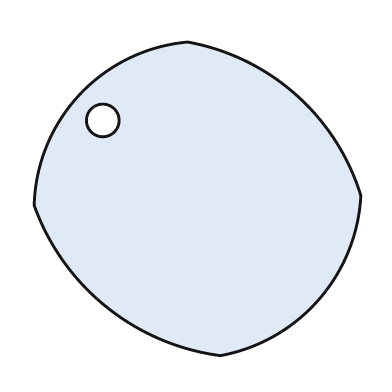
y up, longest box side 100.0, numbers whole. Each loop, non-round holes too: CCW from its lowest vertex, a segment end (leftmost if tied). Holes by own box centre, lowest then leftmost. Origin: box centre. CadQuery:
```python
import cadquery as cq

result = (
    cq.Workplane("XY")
    .moveTo(7.0, -48.0)
    .threePointArc((37.0, -31.0), (50.0, 1.0))
    .threePointArc((30.0, 32.0), (-3.0, 48.0))
    .threePointArc((-36.0, 32.0), (-50.0, -2.0))
    .threePointArc((-28.0, -33.0), (7.0, -48.0))
    .close()
    .moveTo(-29.0, 24.0)
    .circle(5.0)
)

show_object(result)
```